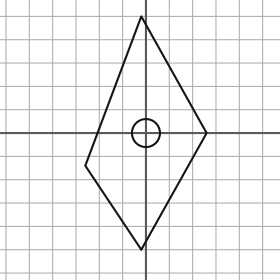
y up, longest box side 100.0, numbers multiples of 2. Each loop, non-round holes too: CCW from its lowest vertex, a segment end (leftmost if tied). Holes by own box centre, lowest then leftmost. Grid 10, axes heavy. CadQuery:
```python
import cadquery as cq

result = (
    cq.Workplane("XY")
    .moveTo(-2.0, -50.0)
    .lineTo(26.0, 0.0)
    .lineTo(-2.0, 50.0)
    .lineTo(-26.0, -14.0)
    .close()
    .moveTo(0.0, 0.0)
    .circle(6.0)
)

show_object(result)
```